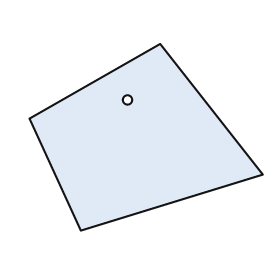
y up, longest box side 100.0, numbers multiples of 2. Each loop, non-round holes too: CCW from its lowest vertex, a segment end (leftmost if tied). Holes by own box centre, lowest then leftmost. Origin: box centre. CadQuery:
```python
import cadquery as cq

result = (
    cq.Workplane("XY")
    .moveTo(-28.0, -40.0)
    .lineTo(50.0, -16.0)
    .lineTo(6.0, 40.0)
    .lineTo(-50.0, 8.0)
    .close()
    .moveTo(-8.0, 16.0)
    .circle(2.0)
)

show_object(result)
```